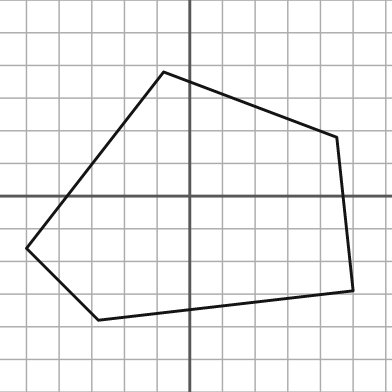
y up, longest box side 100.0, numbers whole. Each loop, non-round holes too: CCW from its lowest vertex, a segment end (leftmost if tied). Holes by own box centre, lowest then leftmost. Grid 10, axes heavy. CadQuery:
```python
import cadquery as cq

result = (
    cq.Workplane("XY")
    .moveTo(-28.0, -38.0)
    .lineTo(50.0, -29.0)
    .lineTo(45.0, 18.0)
    .lineTo(-8.0, 38.0)
    .lineTo(-50.0, -16.0)
    .close()
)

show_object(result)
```